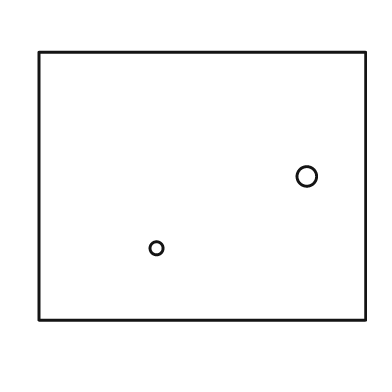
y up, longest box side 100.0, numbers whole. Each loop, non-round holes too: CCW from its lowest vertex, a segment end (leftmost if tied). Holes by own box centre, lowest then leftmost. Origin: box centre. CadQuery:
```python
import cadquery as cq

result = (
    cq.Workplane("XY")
    .moveTo(-50.0, -41.0)
    .lineTo(50.0, -41.0)
    .lineTo(50.0, 41.0)
    .lineTo(-50.0, 41.0)
    .close()
    .moveTo(-14.0, -19.0)
    .circle(2.0)
    .moveTo(32.0, 3.0)
    .circle(3.0)
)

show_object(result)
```